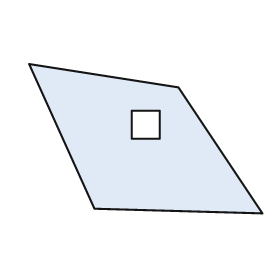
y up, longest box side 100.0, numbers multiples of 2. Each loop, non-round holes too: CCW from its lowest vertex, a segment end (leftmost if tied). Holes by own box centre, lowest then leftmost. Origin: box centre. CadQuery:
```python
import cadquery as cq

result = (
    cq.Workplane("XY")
    .moveTo(50.0, -32.0)
    .lineTo(14.0, 22.0)
    .lineTo(-50.0, 32.0)
    .lineTo(-22.0, -30.0)
    .close()
    .moveTo(-6.0, 0.0)
    .lineTo(6.0, 0.0)
    .lineTo(6.0, 12.0)
    .lineTo(-6.0, 12.0)
    .close()
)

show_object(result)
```